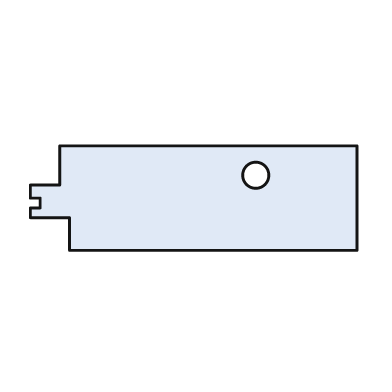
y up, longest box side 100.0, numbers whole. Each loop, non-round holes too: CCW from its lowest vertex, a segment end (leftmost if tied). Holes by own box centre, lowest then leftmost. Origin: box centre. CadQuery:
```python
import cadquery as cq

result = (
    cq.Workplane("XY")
    .moveTo(-38.0, -16.0)
    .lineTo(50.0, -16.0)
    .lineTo(50.0, 16.0)
    .lineTo(-41.0, 16.0)
    .lineTo(-41.0, 4.0)
    .lineTo(-50.0, 4.0)
    .lineTo(-50.0, 0.0)
    .lineTo(-47.0, 0.0)
    .lineTo(-47.0, -3.0)
    .lineTo(-50.0, -3.0)
    .lineTo(-50.0, -6.0)
    .lineTo(-38.0, -6.0)
    .close()
    .moveTo(19.0, 7.0)
    .circle(4.0)
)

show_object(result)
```